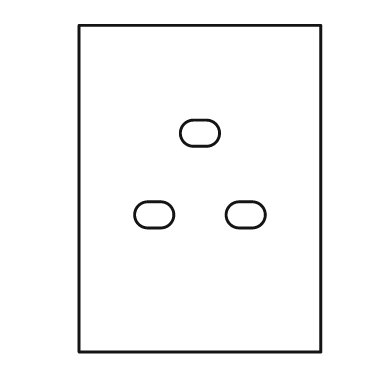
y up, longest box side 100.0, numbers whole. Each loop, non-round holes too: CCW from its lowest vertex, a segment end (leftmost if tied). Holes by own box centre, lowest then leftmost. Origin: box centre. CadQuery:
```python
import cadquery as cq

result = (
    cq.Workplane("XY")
    .moveTo(-37.0, -50.0)
    .lineTo(37.0, -50.0)
    .lineTo(37.0, 50.0)
    .lineTo(-37.0, 50.0)
    .close()
    .moveTo(-16.0, -12.0)
    .lineTo(-12.0, -12.0)
    .threePointArc((-8.0, -8.0), (-12.0, -4.0))
    .lineTo(-16.0, -4.0)
    .threePointArc((-20.0, -8.0), (-16.0, -12.0))
    .close()
    .moveTo(12.0, -12.0)
    .lineTo(16.0, -12.0)
    .threePointArc((20.0, -8.0), (16.0, -4.0))
    .lineTo(12.0, -4.0)
    .threePointArc((8.0, -8.0), (12.0, -12.0))
    .close()
    .moveTo(-2.0, 13.0)
    .lineTo(2.0, 13.0)
    .threePointArc((6.0, 17.0), (2.0, 21.0))
    .lineTo(-2.0, 21.0)
    .threePointArc((-6.0, 17.0), (-2.0, 13.0))
    .close()
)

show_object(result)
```